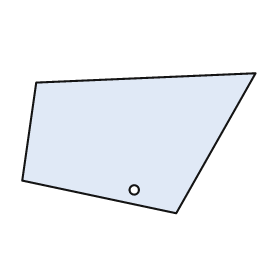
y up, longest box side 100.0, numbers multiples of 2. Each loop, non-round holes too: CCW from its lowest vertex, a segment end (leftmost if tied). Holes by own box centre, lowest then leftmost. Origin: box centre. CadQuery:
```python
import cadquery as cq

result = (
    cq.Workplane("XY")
    .moveTo(16.0, -30.0)
    .lineTo(50.0, 30.0)
    .lineTo(-44.0, 26.0)
    .lineTo(-50.0, -16.0)
    .close()
    .moveTo(-2.0, -20.0)
    .circle(2.0)
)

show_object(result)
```